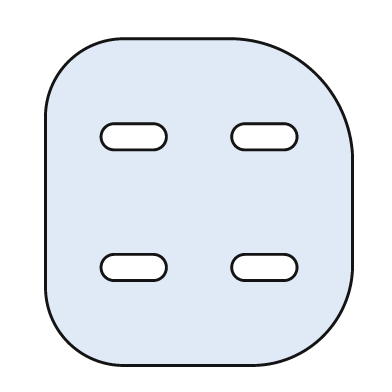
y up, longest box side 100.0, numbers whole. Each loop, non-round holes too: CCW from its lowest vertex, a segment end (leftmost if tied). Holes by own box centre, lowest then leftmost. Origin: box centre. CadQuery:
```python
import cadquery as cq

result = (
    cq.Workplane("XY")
    .moveTo(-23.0, -50.0)
    .lineTo(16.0, -50.0)
    .threePointArc((38.0, -41.0), (47.0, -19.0))
    .lineTo(47.0, 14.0)
    .threePointArc((36.0, 39.0), (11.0, 50.0))
    .lineTo(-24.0, 50.0)
    .threePointArc((-40.0, 43.0), (-47.0, 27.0))
    .lineTo(-47.0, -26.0)
    .threePointArc((-40.0, -43.0), (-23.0, -50.0))
    .close()
    .moveTo(-26.0, -24.0)
    .lineTo(-14.0, -24.0)
    .threePointArc((-10.0, -20.0), (-14.0, -16.0))
    .lineTo(-26.0, -16.0)
    .threePointArc((-30.0, -20.0), (-26.0, -24.0))
    .close()
    .moveTo(14.0, -24.0)
    .lineTo(26.0, -24.0)
    .threePointArc((30.0, -20.0), (26.0, -16.0))
    .lineTo(14.0, -16.0)
    .threePointArc((10.0, -20.0), (14.0, -24.0))
    .close()
    .moveTo(-26.0, 16.0)
    .lineTo(-14.0, 16.0)
    .threePointArc((-10.0, 20.0), (-14.0, 24.0))
    .lineTo(-26.0, 24.0)
    .threePointArc((-30.0, 20.0), (-26.0, 16.0))
    .close()
    .moveTo(14.0, 16.0)
    .lineTo(26.0, 16.0)
    .threePointArc((30.0, 20.0), (26.0, 24.0))
    .lineTo(14.0, 24.0)
    .threePointArc((10.0, 20.0), (14.0, 16.0))
    .close()
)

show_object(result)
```